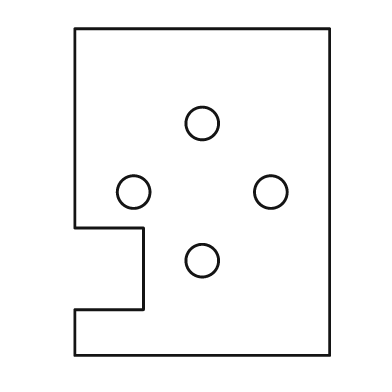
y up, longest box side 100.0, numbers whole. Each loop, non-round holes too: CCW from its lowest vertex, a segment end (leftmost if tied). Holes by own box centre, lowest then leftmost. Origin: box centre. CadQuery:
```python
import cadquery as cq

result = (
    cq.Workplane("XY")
    .moveTo(-39.0, -50.0)
    .lineTo(39.0, -50.0)
    .lineTo(39.0, 50.0)
    .lineTo(-39.0, 50.0)
    .lineTo(-39.0, -11.0)
    .lineTo(-18.0, -11.0)
    .lineTo(-18.0, -36.0)
    .lineTo(-39.0, -36.0)
    .close()
    .moveTo(0.0, -21.0)
    .circle(5.0)
    .moveTo(-21.0, 0.0)
    .circle(5.0)
    .moveTo(21.0, 0.0)
    .circle(5.0)
    .moveTo(0.0, 21.0)
    .circle(5.0)
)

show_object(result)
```